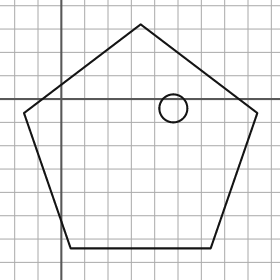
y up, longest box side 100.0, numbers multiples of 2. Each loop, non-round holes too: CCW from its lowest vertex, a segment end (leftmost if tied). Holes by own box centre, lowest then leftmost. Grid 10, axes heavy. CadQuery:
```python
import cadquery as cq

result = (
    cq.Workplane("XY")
    .moveTo(4.0, -64.0)
    .lineTo(64.0, -64.0)
    .lineTo(84.0, -6.0)
    .lineTo(34.0, 32.0)
    .lineTo(-16.0, -6.0)
    .close()
    .moveTo(48.0, -4.0)
    .circle(6.0)
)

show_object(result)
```